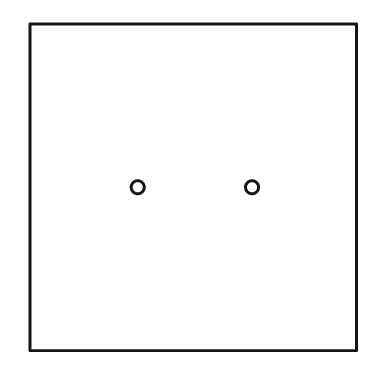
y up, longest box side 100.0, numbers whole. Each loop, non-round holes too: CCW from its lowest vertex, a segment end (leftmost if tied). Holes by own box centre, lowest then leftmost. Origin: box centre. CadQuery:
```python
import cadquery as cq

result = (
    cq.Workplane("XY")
    .moveTo(-50.0, -50.0)
    .lineTo(50.0, -50.0)
    .lineTo(50.0, 50.0)
    .lineTo(-50.0, 50.0)
    .close()
    .moveTo(-17.0, 0.0)
    .circle(2.0)
    .moveTo(18.0, 0.0)
    .circle(2.0)
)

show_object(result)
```